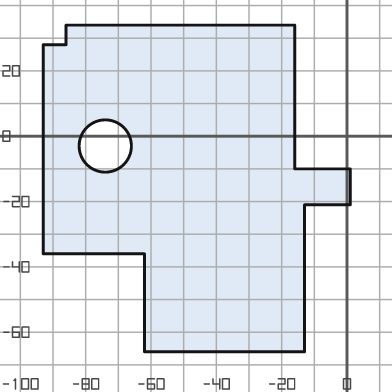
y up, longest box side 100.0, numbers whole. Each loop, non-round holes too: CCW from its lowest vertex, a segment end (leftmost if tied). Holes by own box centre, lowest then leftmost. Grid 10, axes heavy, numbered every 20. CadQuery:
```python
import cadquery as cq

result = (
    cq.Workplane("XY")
    .moveTo(-62.0, -66.0)
    .lineTo(-13.0, -66.0)
    .lineTo(-13.0, -21.0)
    .lineTo(1.0, -21.0)
    .lineTo(1.0, -10.0)
    .lineTo(-16.0, -10.0)
    .lineTo(-16.0, 34.0)
    .lineTo(-86.0, 34.0)
    .lineTo(-86.0, 28.0)
    .lineTo(-93.0, 28.0)
    .lineTo(-93.0, -36.0)
    .lineTo(-62.0, -36.0)
    .close()
    .moveTo(-74.0, -3.0)
    .circle(8.0)
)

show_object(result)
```